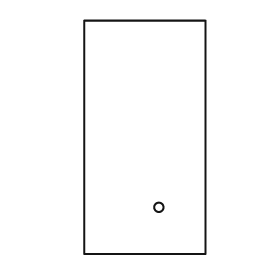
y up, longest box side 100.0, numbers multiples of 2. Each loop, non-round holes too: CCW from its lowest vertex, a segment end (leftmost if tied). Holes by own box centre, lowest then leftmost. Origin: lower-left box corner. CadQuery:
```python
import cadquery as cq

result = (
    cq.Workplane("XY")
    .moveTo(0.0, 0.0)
    .lineTo(52.0, 0.0)
    .lineTo(52.0, 100.0)
    .lineTo(0.0, 100.0)
    .close()
    .moveTo(32.0, 20.0)
    .circle(2.0)
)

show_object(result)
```